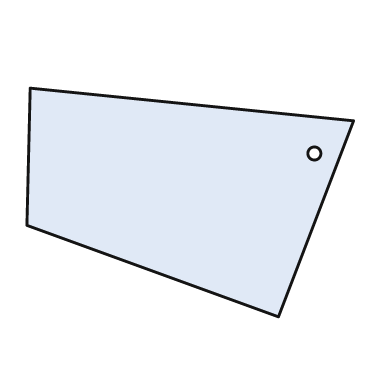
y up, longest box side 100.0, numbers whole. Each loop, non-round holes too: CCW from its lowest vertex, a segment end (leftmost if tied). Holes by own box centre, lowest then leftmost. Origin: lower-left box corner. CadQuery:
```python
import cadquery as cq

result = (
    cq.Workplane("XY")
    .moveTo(77.0, 0.0)
    .lineTo(100.0, 60.0)
    .lineTo(1.0, 70.0)
    .lineTo(0.0, 28.0)
    .close()
    .moveTo(88.0, 50.0)
    .circle(2.0)
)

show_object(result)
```